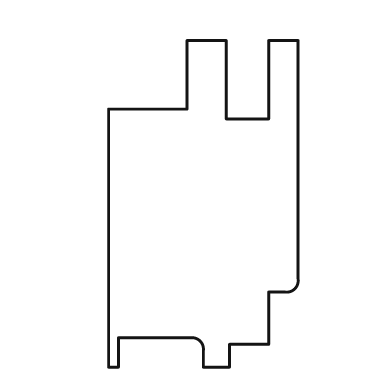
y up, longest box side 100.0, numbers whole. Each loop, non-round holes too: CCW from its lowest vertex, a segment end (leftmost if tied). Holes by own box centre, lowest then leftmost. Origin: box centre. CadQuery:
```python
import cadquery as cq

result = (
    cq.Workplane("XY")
    .moveTo(-29.0, -50.0)
    .lineTo(-26.0, -50.0)
    .lineTo(-26.0, -41.0)
    .lineTo(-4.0, -41.0)
    .threePointArc((-1.0, -42.0), (0.0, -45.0))
    .lineTo(0.0, -50.0)
    .lineTo(8.0, -50.0)
    .lineTo(8.0, -43.0)
    .lineTo(20.0, -43.0)
    .lineTo(20.0, -27.0)
    .lineTo(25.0, -27.0)
    .threePointArc((28.0, -26.0), (29.0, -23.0))
    .lineTo(29.0, 50.0)
    .lineTo(20.0, 50.0)
    .lineTo(20.0, 26.0)
    .lineTo(7.0, 26.0)
    .lineTo(7.0, 50.0)
    .lineTo(-5.0, 50.0)
    .lineTo(-5.0, 29.0)
    .lineTo(-29.0, 29.0)
    .close()
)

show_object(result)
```